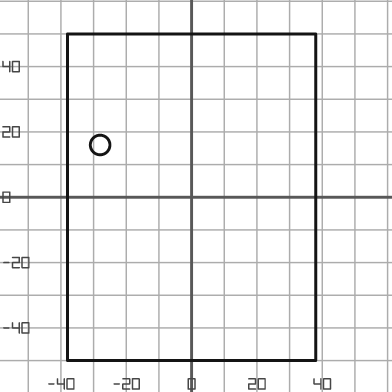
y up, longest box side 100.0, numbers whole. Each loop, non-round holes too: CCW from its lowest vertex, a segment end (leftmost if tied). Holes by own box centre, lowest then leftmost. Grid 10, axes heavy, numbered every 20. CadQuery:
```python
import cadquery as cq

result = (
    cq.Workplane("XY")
    .moveTo(-38.0, -50.0)
    .lineTo(38.0, -50.0)
    .lineTo(38.0, 50.0)
    .lineTo(-38.0, 50.0)
    .close()
    .moveTo(-28.0, 16.0)
    .circle(3.0)
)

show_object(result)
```